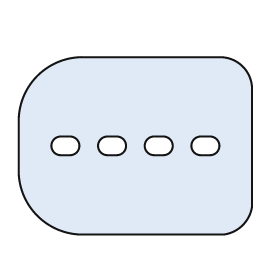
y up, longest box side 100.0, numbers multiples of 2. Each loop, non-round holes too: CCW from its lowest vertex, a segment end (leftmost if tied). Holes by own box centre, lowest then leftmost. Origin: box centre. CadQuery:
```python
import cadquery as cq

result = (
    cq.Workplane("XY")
    .moveTo(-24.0, -38.0)
    .lineTo(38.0, -38.0)
    .threePointArc((46.0, -34.0), (50.0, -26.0))
    .lineTo(50.0, 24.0)
    .threePointArc((46.0, 34.0), (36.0, 38.0))
    .lineTo(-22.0, 38.0)
    .threePointArc((-42.0, 30.0), (-50.0, 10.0))
    .lineTo(-50.0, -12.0)
    .threePointArc((-42.0, -30.0), (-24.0, -38.0))
    .close()
    .moveTo(-32.0, -4.0)
    .lineTo(-28.0, -4.0)
    .threePointArc((-24.0, 0.0), (-28.0, 4.0))
    .lineTo(-32.0, 4.0)
    .threePointArc((-36.0, 0.0), (-32.0, -4.0))
    .close()
    .moveTo(-12.0, -4.0)
    .lineTo(-8.0, -4.0)
    .threePointArc((-4.0, 0.0), (-8.0, 4.0))
    .lineTo(-12.0, 4.0)
    .threePointArc((-16.0, 0.0), (-12.0, -4.0))
    .close()
    .moveTo(8.0, -4.0)
    .lineTo(12.0, -4.0)
    .threePointArc((16.0, 0.0), (12.0, 4.0))
    .lineTo(8.0, 4.0)
    .threePointArc((4.0, 0.0), (8.0, -4.0))
    .close()
    .moveTo(28.0, -4.0)
    .lineTo(32.0, -4.0)
    .threePointArc((36.0, 0.0), (32.0, 4.0))
    .lineTo(28.0, 4.0)
    .threePointArc((24.0, 0.0), (28.0, -4.0))
    .close()
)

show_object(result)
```